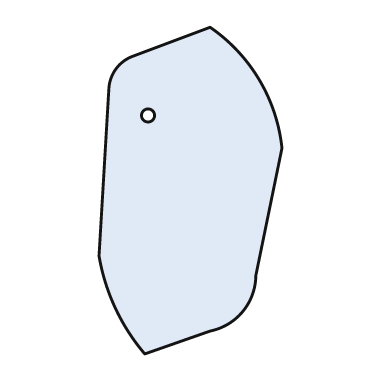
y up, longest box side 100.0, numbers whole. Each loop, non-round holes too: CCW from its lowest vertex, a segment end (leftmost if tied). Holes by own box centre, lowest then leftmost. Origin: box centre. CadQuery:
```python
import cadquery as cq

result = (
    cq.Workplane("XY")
    .moveTo(-14.0, -50.0)
    .lineTo(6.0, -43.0)
    .threePointArc((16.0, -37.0), (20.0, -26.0))
    .lineTo(28.0, 13.0)
    .threePointArc((21.0, 34.0), (6.0, 50.0))
    .lineTo(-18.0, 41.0)
    .threePointArc((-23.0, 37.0), (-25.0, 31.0))
    .lineTo(-28.0, -20.0)
    .threePointArc((-23.0, -36.0), (-14.0, -50.0))
    .close()
    .moveTo(-13.0, 23.0)
    .circle(2.0)
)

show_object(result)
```